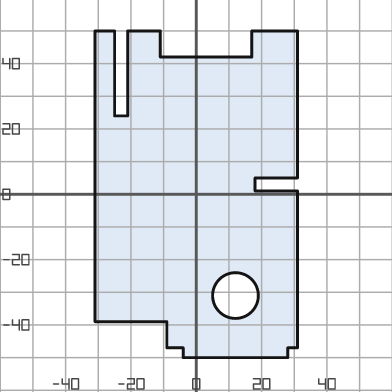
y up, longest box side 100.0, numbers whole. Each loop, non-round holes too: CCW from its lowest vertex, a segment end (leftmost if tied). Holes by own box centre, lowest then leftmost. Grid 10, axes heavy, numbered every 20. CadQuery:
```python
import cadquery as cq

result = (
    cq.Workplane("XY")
    .moveTo(-4.0, -50.0)
    .lineTo(28.0, -50.0)
    .lineTo(28.0, -47.0)
    .lineTo(31.0, -47.0)
    .lineTo(31.0, 1.0)
    .lineTo(18.0, 1.0)
    .lineTo(18.0, 5.0)
    .lineTo(31.0, 5.0)
    .lineTo(31.0, 50.0)
    .lineTo(17.0, 50.0)
    .lineTo(17.0, 42.0)
    .lineTo(-11.0, 42.0)
    .lineTo(-11.0, 50.0)
    .lineTo(-21.0, 50.0)
    .lineTo(-21.0, 24.0)
    .lineTo(-25.0, 24.0)
    .lineTo(-25.0, 50.0)
    .lineTo(-31.0, 50.0)
    .lineTo(-31.0, -39.0)
    .lineTo(-9.0, -39.0)
    .lineTo(-9.0, -47.0)
    .lineTo(-4.0, -47.0)
    .close()
    .moveTo(12.0, -31.0)
    .circle(7.0)
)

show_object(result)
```